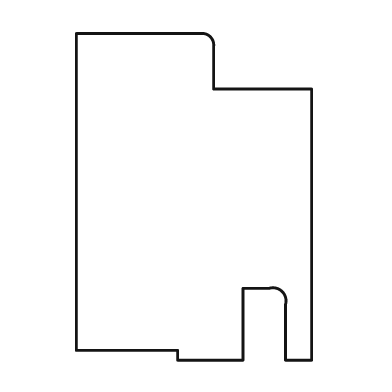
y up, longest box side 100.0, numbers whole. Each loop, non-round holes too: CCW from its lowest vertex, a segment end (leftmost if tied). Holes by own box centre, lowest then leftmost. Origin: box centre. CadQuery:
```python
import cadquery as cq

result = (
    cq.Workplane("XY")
    .moveTo(-5.0, -50.0)
    .lineTo(15.0, -50.0)
    .lineTo(15.0, -28.0)
    .lineTo(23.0, -28.0)
    .threePointArc((27.0, -29.0), (28.0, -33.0))
    .lineTo(28.0, -50.0)
    .lineTo(36.0, -50.0)
    .lineTo(36.0, 33.0)
    .lineTo(6.0, 33.0)
    .lineTo(6.0, 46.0)
    .threePointArc((5.0, 49.0), (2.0, 50.0))
    .lineTo(-36.0, 50.0)
    .lineTo(-36.0, -47.0)
    .lineTo(-5.0, -47.0)
    .close()
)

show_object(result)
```